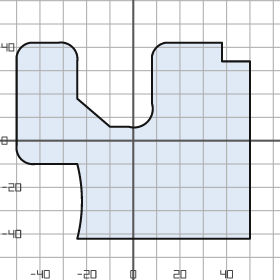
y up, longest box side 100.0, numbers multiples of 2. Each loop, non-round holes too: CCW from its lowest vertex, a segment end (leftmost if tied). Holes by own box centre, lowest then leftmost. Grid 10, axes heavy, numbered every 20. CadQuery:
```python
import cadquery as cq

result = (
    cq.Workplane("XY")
    .moveTo(-24.0, -42.0)
    .lineTo(50.0, -42.0)
    .lineTo(50.0, 34.0)
    .lineTo(38.0, 34.0)
    .lineTo(38.0, 42.0)
    .lineTo(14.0, 42.0)
    .threePointArc((10.0, 40.0), (8.0, 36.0))
    .lineTo(8.0, 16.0)
    .threePointArc((6.0, 8.0), (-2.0, 6.0))
    .lineTo(-10.0, 6.0)
    .lineTo(-24.0, 18.0)
    .lineTo(-24.0, 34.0)
    .threePointArc((-26.0, 40.0), (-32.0, 42.0))
    .lineTo(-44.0, 42.0)
    .threePointArc((-48.0, 40.0), (-50.0, 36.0))
    .lineTo(-50.0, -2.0)
    .threePointArc((-48.0, -8.0), (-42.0, -10.0))
    .lineTo(-24.0, -10.0)
    .threePointArc((-22.0, -26.0), (-24.0, -42.0))
    .close()
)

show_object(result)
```